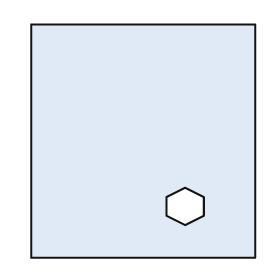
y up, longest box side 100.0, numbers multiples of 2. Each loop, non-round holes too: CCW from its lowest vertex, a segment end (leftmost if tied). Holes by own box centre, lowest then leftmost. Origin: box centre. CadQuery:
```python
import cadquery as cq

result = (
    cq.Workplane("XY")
    .moveTo(-48.0, -50.0)
    .lineTo(48.0, -50.0)
    .lineTo(48.0, 50.0)
    .lineTo(-48.0, 50.0)
    .close()
    .moveTo(18.0, -36.0)
    .lineTo(26.0, -32.0)
    .lineTo(26.0, -24.0)
    .lineTo(18.0, -20.0)
    .lineTo(10.0, -24.0)
    .lineTo(10.0, -32.0)
    .close()
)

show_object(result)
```